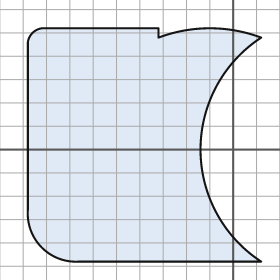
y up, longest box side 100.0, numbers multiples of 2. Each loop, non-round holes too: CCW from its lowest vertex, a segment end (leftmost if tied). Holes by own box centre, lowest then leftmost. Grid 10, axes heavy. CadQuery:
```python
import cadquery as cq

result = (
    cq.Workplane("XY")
    .moveTo(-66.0, -48.0)
    .lineTo(12.0, -48.0)
    .threePointArc((-14.0, 0.0), (12.0, 48.0))
    .threePointArc((-10.0, 52.0), (-32.0, 48.0))
    .lineTo(-32.0, 52.0)
    .lineTo(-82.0, 52.0)
    .threePointArc((-86.0, 50.0), (-88.0, 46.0))
    .lineTo(-88.0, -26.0)
    .threePointArc((-82.0, -42.0), (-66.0, -48.0))
    .close()
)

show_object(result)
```